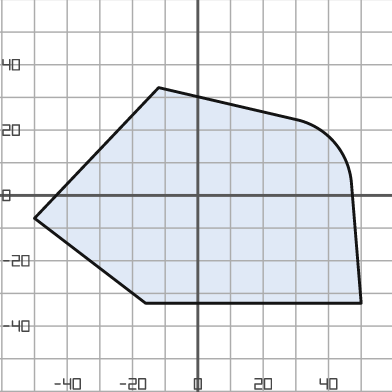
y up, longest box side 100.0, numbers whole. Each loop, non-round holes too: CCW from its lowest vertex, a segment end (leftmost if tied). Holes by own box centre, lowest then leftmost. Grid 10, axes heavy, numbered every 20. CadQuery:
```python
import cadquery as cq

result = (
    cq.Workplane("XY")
    .moveTo(-16.0, -33.0)
    .lineTo(50.0, -33.0)
    .lineTo(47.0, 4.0)
    .threePointArc((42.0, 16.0), (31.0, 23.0))
    .lineTo(-12.0, 33.0)
    .lineTo(-50.0, -7.0)
    .close()
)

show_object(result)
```